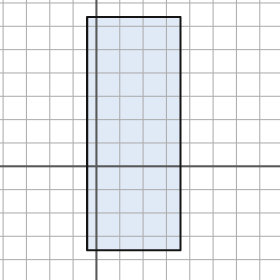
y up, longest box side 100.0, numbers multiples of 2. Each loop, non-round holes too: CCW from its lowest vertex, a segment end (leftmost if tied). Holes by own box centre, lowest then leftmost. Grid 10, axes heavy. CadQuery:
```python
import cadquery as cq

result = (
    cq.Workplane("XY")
    .moveTo(-4.0, -36.0)
    .lineTo(36.0, -36.0)
    .lineTo(36.0, 64.0)
    .lineTo(-4.0, 64.0)
    .close()
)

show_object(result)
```